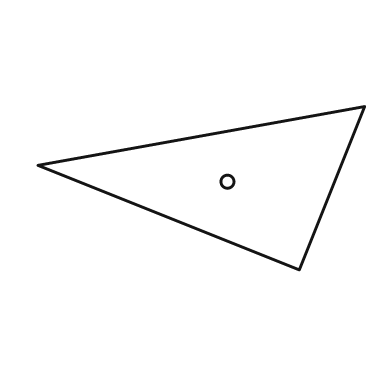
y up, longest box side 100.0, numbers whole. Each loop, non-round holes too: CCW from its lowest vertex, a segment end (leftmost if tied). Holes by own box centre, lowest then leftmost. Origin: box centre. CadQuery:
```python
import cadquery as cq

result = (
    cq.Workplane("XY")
    .moveTo(30.0, -25.0)
    .lineTo(50.0, 25.0)
    .lineTo(-50.0, 7.0)
    .close()
    .moveTo(8.0, 2.0)
    .circle(2.0)
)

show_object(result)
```